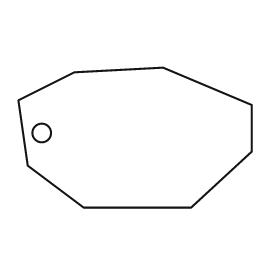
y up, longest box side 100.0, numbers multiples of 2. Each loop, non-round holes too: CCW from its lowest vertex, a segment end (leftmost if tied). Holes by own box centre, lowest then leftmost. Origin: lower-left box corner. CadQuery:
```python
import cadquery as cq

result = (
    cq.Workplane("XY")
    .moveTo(28.0, 0.0)
    .lineTo(74.0, 0.0)
    .lineTo(100.0, 24.0)
    .lineTo(100.0, 44.0)
    .lineTo(62.0, 60.0)
    .lineTo(24.0, 58.0)
    .lineTo(0.0, 46.0)
    .lineTo(4.0, 18.0)
    .close()
    .moveTo(10.0, 32.0)
    .circle(4.0)
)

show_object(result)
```